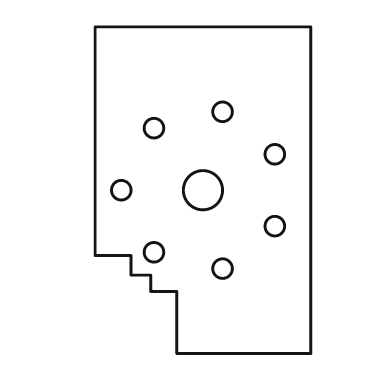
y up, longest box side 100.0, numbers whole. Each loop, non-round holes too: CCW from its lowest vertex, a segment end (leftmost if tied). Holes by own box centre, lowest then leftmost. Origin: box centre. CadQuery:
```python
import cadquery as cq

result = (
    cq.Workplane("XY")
    .moveTo(-8.0, -50.0)
    .lineTo(33.0, -50.0)
    .lineTo(33.0, 50.0)
    .lineTo(-33.0, 50.0)
    .lineTo(-33.0, -20.0)
    .lineTo(-22.0, -20.0)
    .lineTo(-22.0, -26.0)
    .lineTo(-16.0, -26.0)
    .lineTo(-16.0, -31.0)
    .lineTo(-8.0, -31.0)
    .close()
    .moveTo(6.0, -24.0)
    .circle(3.0)
    .moveTo(-15.0, -19.0)
    .circle(3.0)
    .moveTo(22.0, -11.0)
    .circle(3.0)
    .moveTo(-25.0, 0.0)
    .circle(3.0)
    .moveTo(0.0, 0.0)
    .circle(6.0)
    .moveTo(22.0, 11.0)
    .circle(3.0)
    .moveTo(-15.0, 19.0)
    .circle(3.0)
    .moveTo(6.0, 24.0)
    .circle(3.0)
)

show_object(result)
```